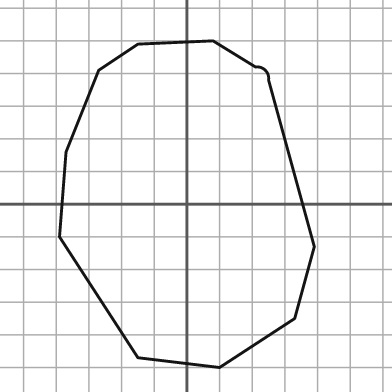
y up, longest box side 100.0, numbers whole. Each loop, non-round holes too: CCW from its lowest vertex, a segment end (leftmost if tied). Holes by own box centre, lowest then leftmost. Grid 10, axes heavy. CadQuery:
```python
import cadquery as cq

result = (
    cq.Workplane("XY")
    .moveTo(10.0, -50.0)
    .lineTo(33.0, -35.0)
    .lineTo(39.0, -13.0)
    .lineTo(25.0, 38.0)
    .threePointArc((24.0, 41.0), (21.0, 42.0))
    .lineTo(8.0, 50.0)
    .lineTo(-15.0, 49.0)
    .lineTo(-27.0, 41.0)
    .lineTo(-37.0, 16.0)
    .lineTo(-39.0, -10.0)
    .lineTo(-15.0, -47.0)
    .close()
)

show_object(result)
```